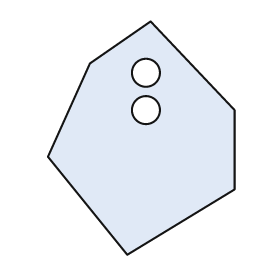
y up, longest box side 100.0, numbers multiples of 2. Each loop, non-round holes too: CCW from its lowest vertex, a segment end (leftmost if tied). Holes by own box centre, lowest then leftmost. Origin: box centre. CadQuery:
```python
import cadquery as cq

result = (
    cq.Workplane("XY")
    .moveTo(-6.0, -50.0)
    .lineTo(40.0, -22.0)
    .lineTo(40.0, 12.0)
    .lineTo(4.0, 50.0)
    .lineTo(-22.0, 32.0)
    .lineTo(-40.0, -8.0)
    .close()
    .moveTo(2.0, 12.0)
    .circle(6.0)
    .moveTo(2.0, 28.0)
    .circle(6.0)
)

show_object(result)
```